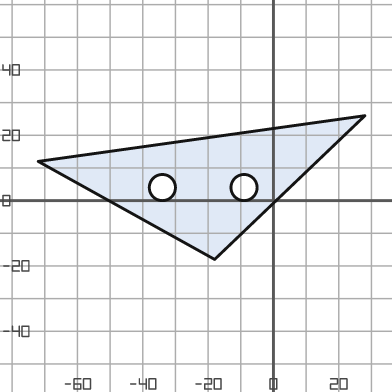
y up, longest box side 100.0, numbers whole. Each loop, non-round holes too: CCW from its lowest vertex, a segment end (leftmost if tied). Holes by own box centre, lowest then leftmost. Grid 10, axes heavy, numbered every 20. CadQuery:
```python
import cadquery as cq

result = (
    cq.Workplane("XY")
    .moveTo(-18.0, -18.0)
    .lineTo(28.0, 26.0)
    .lineTo(-72.0, 12.0)
    .close()
    .moveTo(-34.0, 4.0)
    .circle(4.0)
    .moveTo(-9.0, 4.0)
    .circle(4.0)
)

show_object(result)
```